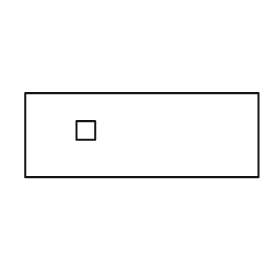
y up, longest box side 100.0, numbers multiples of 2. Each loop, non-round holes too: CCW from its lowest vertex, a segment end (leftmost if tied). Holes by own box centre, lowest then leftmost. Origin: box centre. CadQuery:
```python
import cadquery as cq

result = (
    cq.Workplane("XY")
    .moveTo(-50.0, -18.0)
    .lineTo(50.0, -18.0)
    .lineTo(50.0, 18.0)
    .lineTo(-50.0, 18.0)
    .close()
    .moveTo(-28.0, -2.0)
    .lineTo(-20.0, -2.0)
    .lineTo(-20.0, 6.0)
    .lineTo(-28.0, 6.0)
    .close()
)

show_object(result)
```